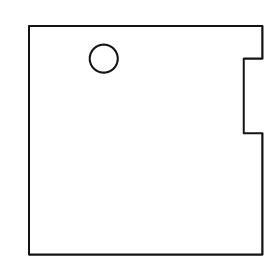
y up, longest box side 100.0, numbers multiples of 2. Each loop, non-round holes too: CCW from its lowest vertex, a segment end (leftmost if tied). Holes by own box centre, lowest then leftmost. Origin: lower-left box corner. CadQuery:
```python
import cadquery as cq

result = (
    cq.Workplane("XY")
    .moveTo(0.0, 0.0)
    .lineTo(100.0, 0.0)
    .lineTo(100.0, 52.0)
    .lineTo(92.0, 52.0)
    .lineTo(92.0, 84.0)
    .lineTo(100.0, 84.0)
    .lineTo(100.0, 98.0)
    .lineTo(0.0, 98.0)
    .close()
    .moveTo(32.0, 84.0)
    .circle(6.0)
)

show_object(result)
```